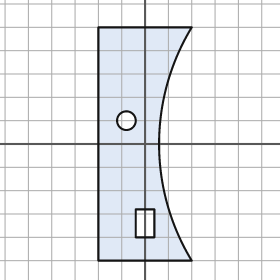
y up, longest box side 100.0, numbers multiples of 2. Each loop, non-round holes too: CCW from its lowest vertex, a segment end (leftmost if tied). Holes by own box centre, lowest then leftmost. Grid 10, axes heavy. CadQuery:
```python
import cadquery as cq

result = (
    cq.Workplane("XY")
    .moveTo(-20.0, -50.0)
    .lineTo(20.0, -50.0)
    .threePointArc((6.0, 0.0), (20.0, 50.0))
    .lineTo(-20.0, 50.0)
    .close()
    .moveTo(-4.0, -40.0)
    .lineTo(4.0, -40.0)
    .lineTo(4.0, -28.0)
    .lineTo(-4.0, -28.0)
    .close()
    .moveTo(-8.0, 10.0)
    .circle(4.0)
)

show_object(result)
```